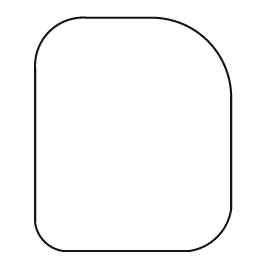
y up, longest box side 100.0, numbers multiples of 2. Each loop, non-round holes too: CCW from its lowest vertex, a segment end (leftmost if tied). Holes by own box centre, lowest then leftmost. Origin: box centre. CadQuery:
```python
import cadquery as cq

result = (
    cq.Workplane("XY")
    .moveTo(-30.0, -50.0)
    .lineTo(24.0, -50.0)
    .threePointArc((36.0, -44.0), (42.0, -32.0))
    .lineTo(42.0, 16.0)
    .threePointArc((32.0, 40.0), (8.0, 50.0))
    .lineTo(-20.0, 50.0)
    .threePointArc((-36.0, 44.0), (-42.0, 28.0))
    .lineTo(-42.0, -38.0)
    .threePointArc((-38.0, -46.0), (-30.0, -50.0))
    .close()
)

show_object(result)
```